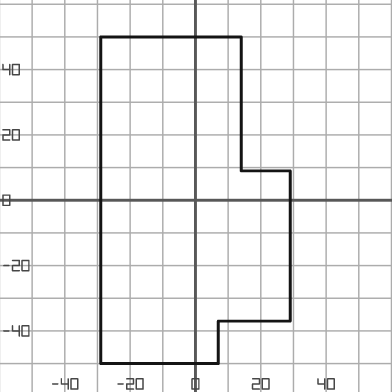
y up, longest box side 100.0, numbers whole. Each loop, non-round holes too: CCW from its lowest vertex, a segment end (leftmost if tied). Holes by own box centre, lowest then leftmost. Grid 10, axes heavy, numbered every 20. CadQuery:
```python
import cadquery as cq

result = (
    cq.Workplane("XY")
    .moveTo(-29.0, -50.0)
    .lineTo(7.0, -50.0)
    .lineTo(7.0, -37.0)
    .lineTo(29.0, -37.0)
    .lineTo(29.0, 9.0)
    .lineTo(14.0, 9.0)
    .lineTo(14.0, 50.0)
    .lineTo(-29.0, 50.0)
    .close()
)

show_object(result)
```